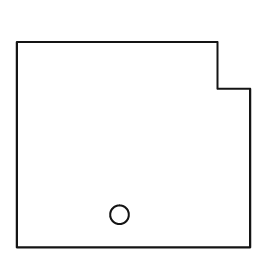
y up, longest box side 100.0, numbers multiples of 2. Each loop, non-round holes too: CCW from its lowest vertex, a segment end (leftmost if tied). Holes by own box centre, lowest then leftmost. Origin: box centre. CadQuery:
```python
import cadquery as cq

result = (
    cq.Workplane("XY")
    .moveTo(-50.0, -44.0)
    .lineTo(50.0, -44.0)
    .lineTo(50.0, 24.0)
    .lineTo(36.0, 24.0)
    .lineTo(36.0, 44.0)
    .lineTo(-50.0, 44.0)
    .close()
    .moveTo(-6.0, -30.0)
    .circle(4.0)
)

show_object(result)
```